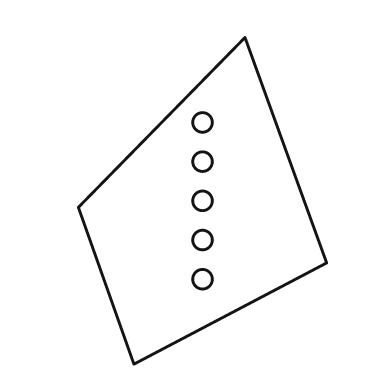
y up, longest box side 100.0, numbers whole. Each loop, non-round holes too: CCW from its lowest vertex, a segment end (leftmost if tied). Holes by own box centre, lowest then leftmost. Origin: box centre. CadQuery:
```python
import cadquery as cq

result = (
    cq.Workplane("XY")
    .moveTo(-21.0, -50.0)
    .lineTo(38.0, -19.0)
    .lineTo(13.0, 50.0)
    .lineTo(-38.0, -2.0)
    .close()
    .moveTo(0.0, -24.0)
    .circle(3.0)
    .moveTo(0.0, -12.0)
    .circle(3.0)
    .moveTo(0.0, 0.0)
    .circle(3.0)
    .moveTo(0.0, 12.0)
    .circle(3.0)
    .moveTo(0.0, 24.0)
    .circle(3.0)
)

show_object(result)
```